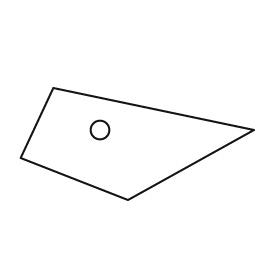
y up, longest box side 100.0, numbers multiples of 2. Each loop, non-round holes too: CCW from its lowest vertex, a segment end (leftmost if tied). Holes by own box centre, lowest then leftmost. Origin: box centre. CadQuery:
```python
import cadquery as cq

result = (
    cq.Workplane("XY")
    .moveTo(-4.0, -24.0)
    .lineTo(50.0, 6.0)
    .lineTo(-36.0, 24.0)
    .lineTo(-50.0, -6.0)
    .close()
    .moveTo(-16.0, 6.0)
    .circle(4.0)
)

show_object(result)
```